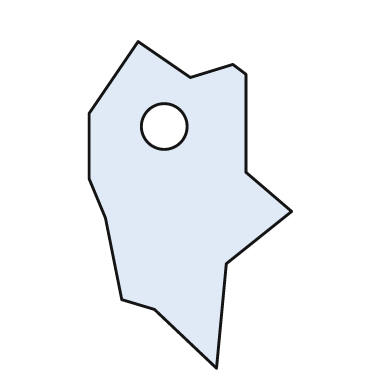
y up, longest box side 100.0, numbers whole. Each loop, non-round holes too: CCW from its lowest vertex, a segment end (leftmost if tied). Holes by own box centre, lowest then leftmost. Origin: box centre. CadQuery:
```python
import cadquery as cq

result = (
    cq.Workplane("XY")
    .moveTo(8.0, -50.0)
    .lineTo(11.0, -18.0)
    .lineTo(31.0, -2.0)
    .lineTo(17.0, 10.0)
    .lineTo(17.0, 40.0)
    .lineTo(13.0, 43.0)
    .lineTo(0.0, 39.0)
    .lineTo(-16.0, 50.0)
    .lineTo(-31.0, 28.0)
    .lineTo(-31.0, 8.0)
    .lineTo(-26.0, -4.0)
    .lineTo(-21.0, -29.0)
    .lineTo(-11.0, -32.0)
    .close()
    .moveTo(-8.0, 24.0)
    .circle(7.0)
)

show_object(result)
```